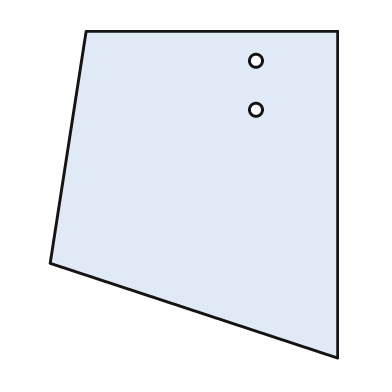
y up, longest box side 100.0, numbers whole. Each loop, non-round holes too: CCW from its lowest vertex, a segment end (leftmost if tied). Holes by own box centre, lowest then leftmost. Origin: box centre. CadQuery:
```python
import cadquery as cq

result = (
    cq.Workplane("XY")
    .moveTo(44.0, -50.0)
    .lineTo(44.0, 50.0)
    .lineTo(-33.0, 50.0)
    .lineTo(-44.0, -21.0)
    .close()
    .moveTo(19.0, 26.0)
    .circle(2.0)
    .moveTo(19.0, 41.0)
    .circle(2.0)
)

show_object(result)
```